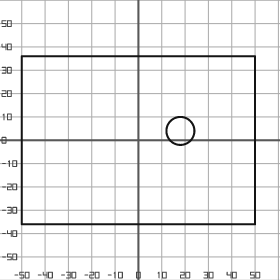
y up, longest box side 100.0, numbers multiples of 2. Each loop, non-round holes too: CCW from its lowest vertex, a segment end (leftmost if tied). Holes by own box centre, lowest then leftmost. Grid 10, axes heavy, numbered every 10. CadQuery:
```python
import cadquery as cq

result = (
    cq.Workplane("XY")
    .moveTo(-50.0, -36.0)
    .lineTo(50.0, -36.0)
    .lineTo(50.0, 36.0)
    .lineTo(-50.0, 36.0)
    .close()
    .moveTo(18.0, 4.0)
    .circle(6.0)
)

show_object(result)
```